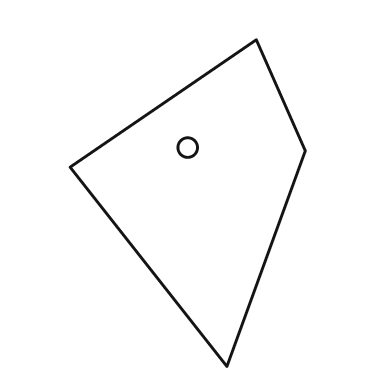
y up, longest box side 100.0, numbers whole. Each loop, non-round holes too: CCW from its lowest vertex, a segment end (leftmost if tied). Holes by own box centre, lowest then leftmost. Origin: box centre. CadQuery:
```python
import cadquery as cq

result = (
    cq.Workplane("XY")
    .moveTo(12.0, -50.0)
    .lineTo(36.0, 16.0)
    .lineTo(21.0, 50.0)
    .lineTo(-36.0, 11.0)
    .close()
    .moveTo(0.0, 17.0)
    .circle(3.0)
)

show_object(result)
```